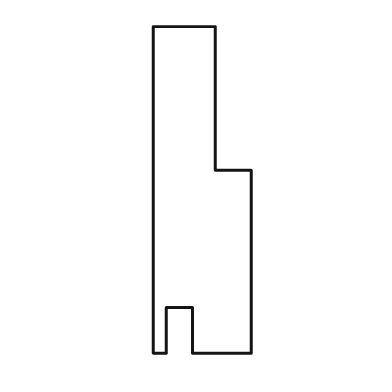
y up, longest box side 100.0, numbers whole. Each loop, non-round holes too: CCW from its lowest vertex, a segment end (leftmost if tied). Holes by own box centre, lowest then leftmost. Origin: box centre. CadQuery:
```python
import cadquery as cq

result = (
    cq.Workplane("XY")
    .moveTo(-15.0, -50.0)
    .lineTo(-11.0, -50.0)
    .lineTo(-11.0, -36.0)
    .lineTo(-3.0, -36.0)
    .lineTo(-3.0, -50.0)
    .lineTo(15.0, -50.0)
    .lineTo(15.0, 6.0)
    .lineTo(4.0, 6.0)
    .lineTo(4.0, 50.0)
    .lineTo(-15.0, 50.0)
    .close()
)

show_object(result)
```